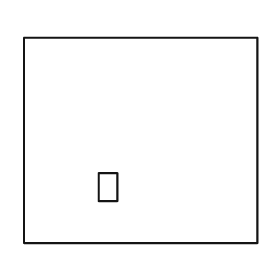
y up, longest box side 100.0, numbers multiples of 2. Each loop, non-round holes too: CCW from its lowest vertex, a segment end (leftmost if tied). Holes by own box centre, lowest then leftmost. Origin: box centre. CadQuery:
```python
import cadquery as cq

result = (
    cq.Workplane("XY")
    .moveTo(-50.0, -44.0)
    .lineTo(50.0, -44.0)
    .lineTo(50.0, 44.0)
    .lineTo(-50.0, 44.0)
    .close()
    .moveTo(-18.0, -26.0)
    .lineTo(-10.0, -26.0)
    .lineTo(-10.0, -14.0)
    .lineTo(-18.0, -14.0)
    .close()
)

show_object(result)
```